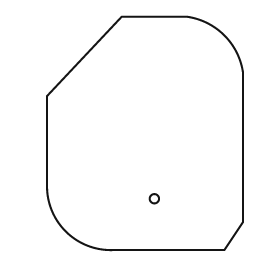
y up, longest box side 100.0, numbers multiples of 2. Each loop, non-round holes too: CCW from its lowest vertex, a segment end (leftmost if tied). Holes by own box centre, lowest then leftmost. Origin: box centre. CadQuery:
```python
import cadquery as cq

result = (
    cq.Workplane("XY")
    .moveTo(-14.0, -50.0)
    .lineTo(34.0, -50.0)
    .lineTo(42.0, -38.0)
    .lineTo(42.0, 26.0)
    .threePointArc((34.0, 42.0), (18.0, 50.0))
    .lineTo(-10.0, 50.0)
    .lineTo(-42.0, 16.0)
    .lineTo(-42.0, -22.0)
    .threePointArc((-34.0, -42.0), (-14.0, -50.0))
    .close()
    .moveTo(4.0, -28.0)
    .circle(2.0)
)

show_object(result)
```